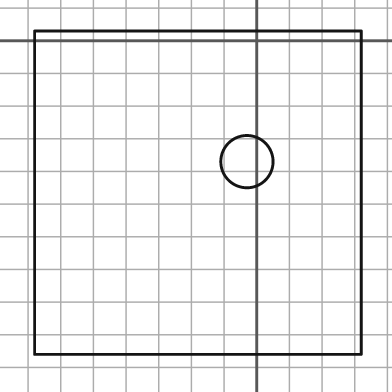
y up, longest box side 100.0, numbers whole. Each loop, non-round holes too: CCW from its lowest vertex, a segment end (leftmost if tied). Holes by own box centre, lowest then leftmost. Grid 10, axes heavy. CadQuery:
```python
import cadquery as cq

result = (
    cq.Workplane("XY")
    .moveTo(-68.0, -96.0)
    .lineTo(32.0, -96.0)
    .lineTo(32.0, 3.0)
    .lineTo(-68.0, 3.0)
    .close()
    .moveTo(-3.0, -37.0)
    .circle(8.0)
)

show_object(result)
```